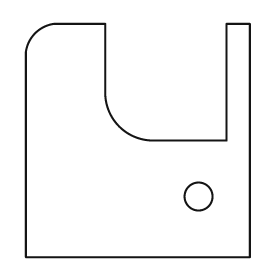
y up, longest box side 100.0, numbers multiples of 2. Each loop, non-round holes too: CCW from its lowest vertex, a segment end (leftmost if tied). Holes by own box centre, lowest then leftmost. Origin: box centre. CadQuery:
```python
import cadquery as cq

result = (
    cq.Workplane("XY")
    .moveTo(-48.0, -50.0)
    .lineTo(48.0, -50.0)
    .lineTo(48.0, 50.0)
    .lineTo(38.0, 50.0)
    .lineTo(38.0, 0.0)
    .lineTo(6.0, 0.0)
    .threePointArc((-8.0, 6.0), (-14.0, 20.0))
    .lineTo(-14.0, 50.0)
    .lineTo(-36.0, 50.0)
    .threePointArc((-44.0, 46.0), (-48.0, 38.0))
    .close()
    .moveTo(26.0, -24.0)
    .circle(6.0)
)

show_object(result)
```